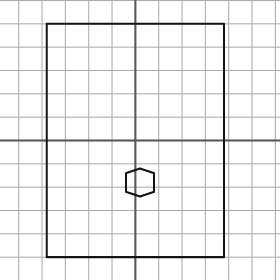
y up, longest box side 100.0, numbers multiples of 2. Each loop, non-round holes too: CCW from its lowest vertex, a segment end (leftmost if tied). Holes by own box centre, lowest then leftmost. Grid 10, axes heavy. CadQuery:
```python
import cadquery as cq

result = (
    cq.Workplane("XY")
    .moveTo(-38.0, -50.0)
    .lineTo(38.0, -50.0)
    .lineTo(38.0, 50.0)
    .lineTo(-38.0, 50.0)
    .close()
    .moveTo(2.0, -24.0)
    .lineTo(8.0, -22.0)
    .lineTo(8.0, -14.0)
    .lineTo(2.0, -12.0)
    .lineTo(-4.0, -14.0)
    .lineTo(-4.0, -22.0)
    .close()
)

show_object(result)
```